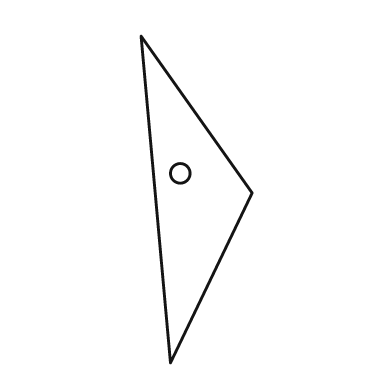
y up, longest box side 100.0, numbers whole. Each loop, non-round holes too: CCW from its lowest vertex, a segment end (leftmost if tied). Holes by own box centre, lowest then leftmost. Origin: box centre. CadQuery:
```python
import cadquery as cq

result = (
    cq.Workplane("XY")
    .moveTo(-8.0, -50.0)
    .lineTo(17.0, 2.0)
    .lineTo(-17.0, 50.0)
    .close()
    .moveTo(-5.0, 8.0)
    .circle(3.0)
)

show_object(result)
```